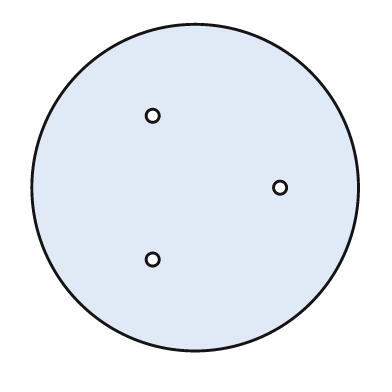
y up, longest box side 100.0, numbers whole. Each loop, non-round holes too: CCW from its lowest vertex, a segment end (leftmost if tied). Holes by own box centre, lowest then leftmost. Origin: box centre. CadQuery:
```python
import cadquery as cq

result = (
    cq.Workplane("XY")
    .moveTo(0.0, 0.0)
    .circle(50.0)
    .moveTo(-13.0, -22.0)
    .circle(2.0)
    .moveTo(26.0, 0.0)
    .circle(2.0)
    .moveTo(-13.0, 22.0)
    .circle(2.0)
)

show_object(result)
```